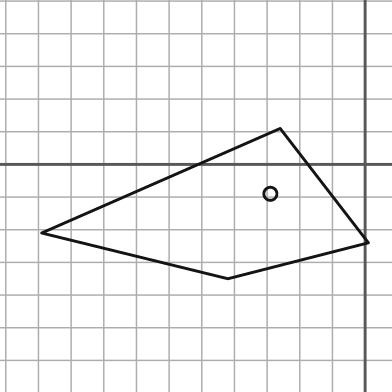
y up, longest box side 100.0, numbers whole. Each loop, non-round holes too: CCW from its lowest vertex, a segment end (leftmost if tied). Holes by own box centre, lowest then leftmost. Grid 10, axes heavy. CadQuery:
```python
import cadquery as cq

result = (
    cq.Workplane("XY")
    .moveTo(-42.0, -35.0)
    .lineTo(1.0, -24.0)
    .lineTo(-26.0, 11.0)
    .lineTo(-99.0, -21.0)
    .close()
    .moveTo(-29.0, -9.0)
    .circle(2.0)
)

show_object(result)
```